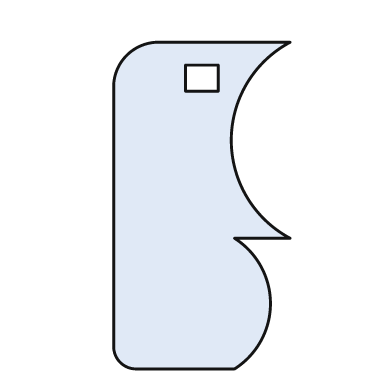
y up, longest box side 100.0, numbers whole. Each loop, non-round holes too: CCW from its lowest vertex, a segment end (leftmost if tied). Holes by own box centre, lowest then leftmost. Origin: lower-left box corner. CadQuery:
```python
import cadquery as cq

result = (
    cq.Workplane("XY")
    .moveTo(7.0, 0.0)
    .lineTo(37.0, 0.0)
    .threePointArc((48.0, 20.0), (37.0, 40.0))
    .lineTo(54.0, 40.0)
    .threePointArc((36.0, 70.0), (54.0, 100.0))
    .lineTo(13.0, 100.0)
    .threePointArc((4.0, 96.0), (0.0, 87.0))
    .lineTo(0.0, 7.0)
    .threePointArc((2.0, 2.0), (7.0, 0.0))
    .close()
    .moveTo(22.0, 85.0)
    .lineTo(32.0, 85.0)
    .lineTo(32.0, 93.0)
    .lineTo(22.0, 93.0)
    .close()
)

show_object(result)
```